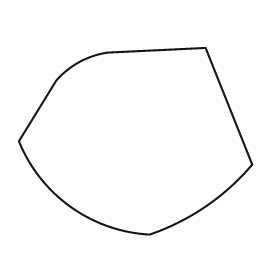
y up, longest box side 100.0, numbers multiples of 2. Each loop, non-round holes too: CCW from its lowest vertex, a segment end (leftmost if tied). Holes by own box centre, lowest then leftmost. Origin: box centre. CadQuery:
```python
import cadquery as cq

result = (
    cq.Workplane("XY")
    .moveTo(6.0, -40.0)
    .threePointArc((30.0, -28.0), (50.0, -10.0))
    .lineTo(30.0, 40.0)
    .lineTo(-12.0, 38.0)
    .threePointArc((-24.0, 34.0), (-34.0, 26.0))
    .lineTo(-50.0, 0.0)
    .threePointArc((-28.0, -28.0), (6.0, -40.0))
    .close()
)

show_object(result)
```